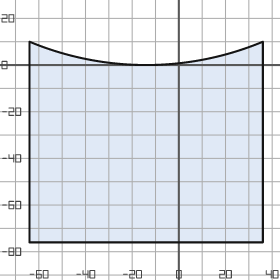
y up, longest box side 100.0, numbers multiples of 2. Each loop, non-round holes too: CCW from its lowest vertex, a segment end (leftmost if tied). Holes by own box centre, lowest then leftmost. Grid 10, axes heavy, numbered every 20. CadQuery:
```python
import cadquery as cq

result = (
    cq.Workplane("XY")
    .moveTo(-64.0, -76.0)
    .lineTo(36.0, -76.0)
    .lineTo(36.0, 10.0)
    .threePointArc((-14.0, 0.0), (-64.0, 10.0))
    .close()
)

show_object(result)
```